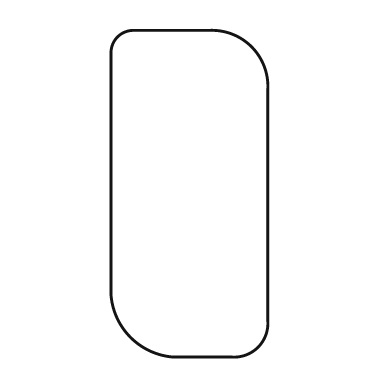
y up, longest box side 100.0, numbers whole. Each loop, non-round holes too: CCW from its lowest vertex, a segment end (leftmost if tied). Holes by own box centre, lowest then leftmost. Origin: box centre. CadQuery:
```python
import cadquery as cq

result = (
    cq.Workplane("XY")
    .moveTo(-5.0, -50.0)
    .lineTo(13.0, -50.0)
    .threePointArc((21.0, -47.0), (24.0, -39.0))
    .lineTo(24.0, 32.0)
    .threePointArc((19.0, 45.0), (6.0, 50.0))
    .lineTo(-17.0, 50.0)
    .threePointArc((-22.0, 48.0), (-24.0, 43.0))
    .lineTo(-24.0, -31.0)
    .threePointArc((-18.0, -44.0), (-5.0, -50.0))
    .close()
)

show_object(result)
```